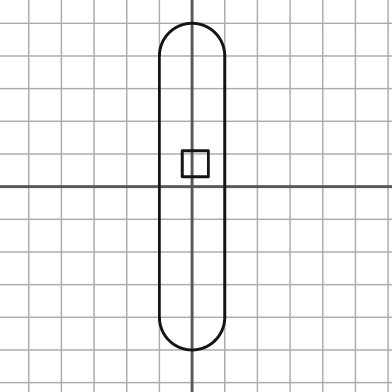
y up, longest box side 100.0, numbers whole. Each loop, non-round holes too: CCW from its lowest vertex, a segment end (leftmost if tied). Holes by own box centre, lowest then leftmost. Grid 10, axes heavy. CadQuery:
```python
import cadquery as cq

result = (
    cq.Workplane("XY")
    .moveTo(-10.0, -40.0)
    .threePointArc((0.0, -50.0), (10.0, -40.0))
    .lineTo(10.0, 40.0)
    .threePointArc((0.0, 50.0), (-10.0, 40.0))
    .close()
    .moveTo(-3.0, 3.0)
    .lineTo(5.0, 3.0)
    .lineTo(5.0, 11.0)
    .lineTo(-3.0, 11.0)
    .close()
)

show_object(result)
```